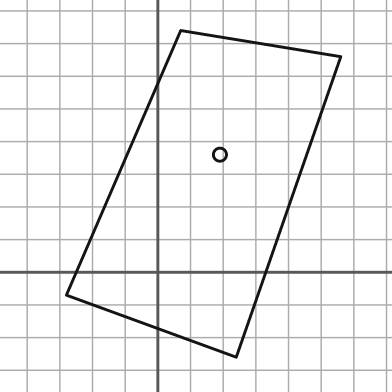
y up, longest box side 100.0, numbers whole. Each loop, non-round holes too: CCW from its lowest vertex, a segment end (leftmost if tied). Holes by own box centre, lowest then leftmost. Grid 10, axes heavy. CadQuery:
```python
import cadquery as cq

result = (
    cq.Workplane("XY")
    .moveTo(24.0, -26.0)
    .lineTo(56.0, 66.0)
    .lineTo(7.0, 74.0)
    .lineTo(-28.0, -7.0)
    .close()
    .moveTo(19.0, 36.0)
    .circle(2.0)
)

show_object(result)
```